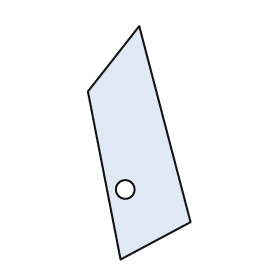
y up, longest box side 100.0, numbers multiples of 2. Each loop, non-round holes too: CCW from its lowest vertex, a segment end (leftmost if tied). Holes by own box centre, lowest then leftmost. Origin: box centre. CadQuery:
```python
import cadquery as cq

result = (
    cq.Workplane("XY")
    .moveTo(-8.0, -50.0)
    .lineTo(22.0, -34.0)
    .lineTo(0.0, 50.0)
    .lineTo(-22.0, 22.0)
    .close()
    .moveTo(-6.0, -20.0)
    .circle(4.0)
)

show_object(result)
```